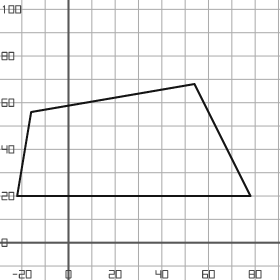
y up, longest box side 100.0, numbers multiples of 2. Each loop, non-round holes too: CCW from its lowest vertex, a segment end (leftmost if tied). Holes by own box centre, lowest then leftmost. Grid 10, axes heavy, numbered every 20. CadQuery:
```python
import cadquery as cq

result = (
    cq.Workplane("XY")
    .moveTo(-22.0, 20.0)
    .lineTo(78.0, 20.0)
    .lineTo(54.0, 68.0)
    .lineTo(-16.0, 56.0)
    .close()
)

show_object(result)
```